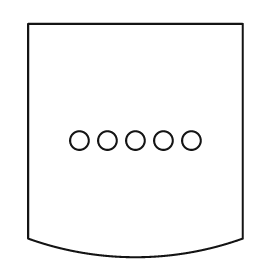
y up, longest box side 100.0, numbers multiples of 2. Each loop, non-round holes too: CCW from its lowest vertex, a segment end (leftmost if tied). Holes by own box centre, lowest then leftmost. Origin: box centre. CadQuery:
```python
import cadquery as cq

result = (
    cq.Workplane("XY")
    .moveTo(-46.0, -42.0)
    .threePointArc((0.0, -50.0), (46.0, -42.0))
    .lineTo(46.0, 50.0)
    .lineTo(-46.0, 50.0)
    .close()
    .moveTo(-24.0, 0.0)
    .circle(4.0)
    .moveTo(-12.0, 0.0)
    .circle(4.0)
    .moveTo(0.0, 0.0)
    .circle(4.0)
    .moveTo(12.0, 0.0)
    .circle(4.0)
    .moveTo(24.0, 0.0)
    .circle(4.0)
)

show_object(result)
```